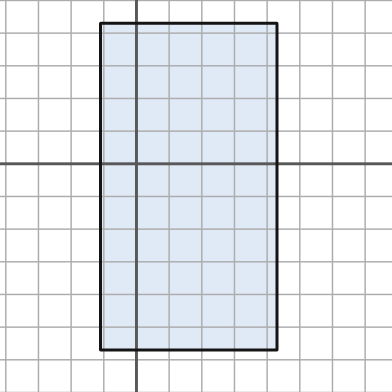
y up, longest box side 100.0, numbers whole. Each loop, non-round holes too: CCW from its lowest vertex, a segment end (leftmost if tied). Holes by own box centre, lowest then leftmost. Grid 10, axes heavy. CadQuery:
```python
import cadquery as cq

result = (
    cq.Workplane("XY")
    .moveTo(-11.0, -57.0)
    .lineTo(43.0, -57.0)
    .lineTo(43.0, 43.0)
    .lineTo(-11.0, 43.0)
    .close()
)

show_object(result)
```